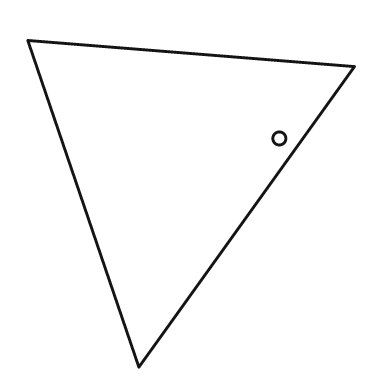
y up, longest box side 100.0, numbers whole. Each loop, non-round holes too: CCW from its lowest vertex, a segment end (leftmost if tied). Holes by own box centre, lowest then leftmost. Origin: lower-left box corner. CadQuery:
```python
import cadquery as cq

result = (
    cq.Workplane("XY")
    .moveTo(34.0, 0.0)
    .lineTo(100.0, 92.0)
    .lineTo(0.0, 100.0)
    .close()
    .moveTo(77.0, 70.0)
    .circle(2.0)
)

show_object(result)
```